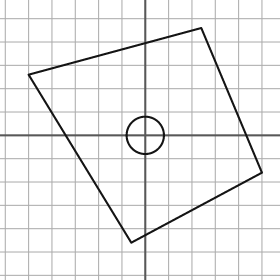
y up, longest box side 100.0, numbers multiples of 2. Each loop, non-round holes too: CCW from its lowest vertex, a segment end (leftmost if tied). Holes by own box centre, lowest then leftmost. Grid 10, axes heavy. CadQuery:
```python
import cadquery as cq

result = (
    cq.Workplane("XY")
    .moveTo(-6.0, -46.0)
    .lineTo(50.0, -16.0)
    .lineTo(24.0, 46.0)
    .lineTo(-50.0, 26.0)
    .close()
    .moveTo(0.0, 0.0)
    .circle(8.0)
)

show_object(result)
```